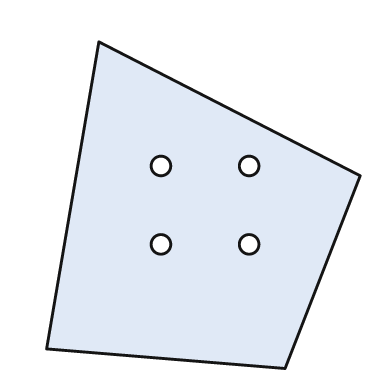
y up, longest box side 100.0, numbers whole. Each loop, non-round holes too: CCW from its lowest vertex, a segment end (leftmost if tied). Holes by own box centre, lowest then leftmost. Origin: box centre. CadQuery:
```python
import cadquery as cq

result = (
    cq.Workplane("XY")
    .moveTo(25.0, -50.0)
    .lineTo(48.0, 9.0)
    .lineTo(-32.0, 50.0)
    .lineTo(-48.0, -44.0)
    .close()
    .moveTo(-13.0, -12.0)
    .circle(3.0)
    .moveTo(14.0, -12.0)
    .circle(3.0)
    .moveTo(-13.0, 12.0)
    .circle(3.0)
    .moveTo(14.0, 12.0)
    .circle(3.0)
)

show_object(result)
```